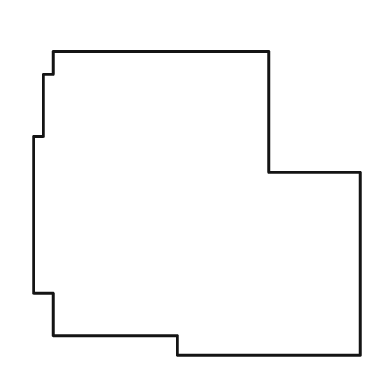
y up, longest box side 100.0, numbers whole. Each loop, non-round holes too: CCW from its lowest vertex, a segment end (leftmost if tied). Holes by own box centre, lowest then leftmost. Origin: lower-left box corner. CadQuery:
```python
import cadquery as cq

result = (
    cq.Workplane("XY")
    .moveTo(44.0, 0.0)
    .lineTo(100.0, 0.0)
    .lineTo(100.0, 56.0)
    .lineTo(72.0, 56.0)
    .lineTo(72.0, 93.0)
    .lineTo(6.0, 93.0)
    .lineTo(6.0, 86.0)
    .lineTo(3.0, 86.0)
    .lineTo(3.0, 67.0)
    .lineTo(0.0, 67.0)
    .lineTo(0.0, 19.0)
    .lineTo(6.0, 19.0)
    .lineTo(6.0, 6.0)
    .lineTo(44.0, 6.0)
    .close()
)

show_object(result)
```